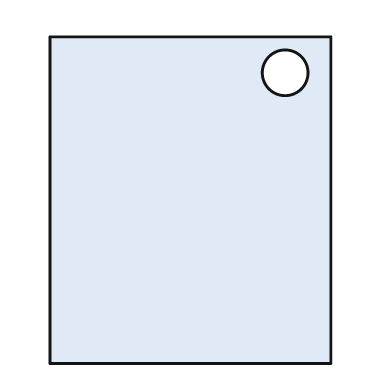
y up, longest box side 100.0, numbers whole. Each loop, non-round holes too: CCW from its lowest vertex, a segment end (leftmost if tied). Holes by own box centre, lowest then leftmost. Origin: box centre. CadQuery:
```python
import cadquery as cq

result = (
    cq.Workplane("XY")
    .moveTo(-43.0, -50.0)
    .lineTo(43.0, -50.0)
    .lineTo(43.0, 50.0)
    .lineTo(-43.0, 50.0)
    .close()
    .moveTo(29.0, 39.0)
    .circle(7.0)
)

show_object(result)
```